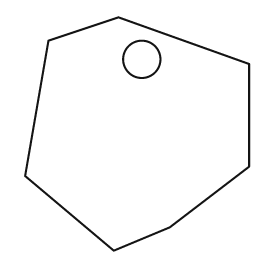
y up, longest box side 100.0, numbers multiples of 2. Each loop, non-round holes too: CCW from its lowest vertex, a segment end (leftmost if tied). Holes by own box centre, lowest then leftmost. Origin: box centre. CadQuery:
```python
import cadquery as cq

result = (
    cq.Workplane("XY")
    .moveTo(-10.0, -50.0)
    .lineTo(14.0, -40.0)
    .lineTo(48.0, -14.0)
    .lineTo(48.0, 30.0)
    .lineTo(-8.0, 50.0)
    .lineTo(-38.0, 40.0)
    .lineTo(-48.0, -18.0)
    .close()
    .moveTo(2.0, 32.0)
    .circle(8.0)
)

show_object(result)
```